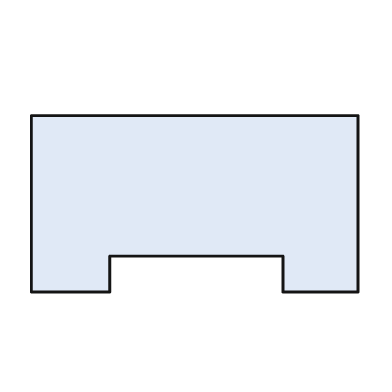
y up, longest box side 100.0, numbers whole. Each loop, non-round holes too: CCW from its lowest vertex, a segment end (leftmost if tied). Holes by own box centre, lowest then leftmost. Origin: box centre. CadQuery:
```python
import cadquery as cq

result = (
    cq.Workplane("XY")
    .moveTo(-50.0, -27.0)
    .lineTo(-26.0, -27.0)
    .lineTo(-26.0, -16.0)
    .lineTo(27.0, -16.0)
    .lineTo(27.0, -27.0)
    .lineTo(50.0, -27.0)
    .lineTo(50.0, 27.0)
    .lineTo(-50.0, 27.0)
    .close()
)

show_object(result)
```